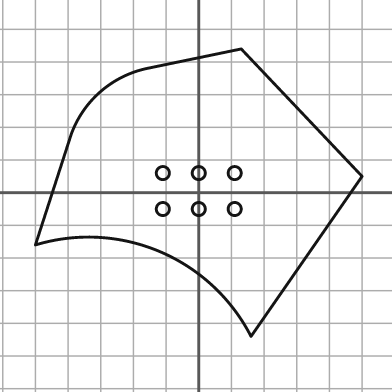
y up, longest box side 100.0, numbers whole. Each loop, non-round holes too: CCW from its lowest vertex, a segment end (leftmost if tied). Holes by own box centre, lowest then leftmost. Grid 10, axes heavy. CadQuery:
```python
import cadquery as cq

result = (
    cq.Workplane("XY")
    .moveTo(16.0, -44.0)
    .lineTo(50.0, 5.0)
    .lineTo(13.0, 44.0)
    .lineTo(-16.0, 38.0)
    .threePointArc((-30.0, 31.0), (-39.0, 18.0))
    .lineTo(-50.0, -16.0)
    .threePointArc((-12.0, -18.0), (16.0, -44.0))
    .close()
    .moveTo(-11.0, -5.0)
    .circle(2.0)
    .moveTo(0.0, -5.0)
    .circle(2.0)
    .moveTo(11.0, -5.0)
    .circle(2.0)
    .moveTo(-11.0, 6.0)
    .circle(2.0)
    .moveTo(0.0, 6.0)
    .circle(2.0)
    .moveTo(11.0, 6.0)
    .circle(2.0)
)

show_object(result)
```